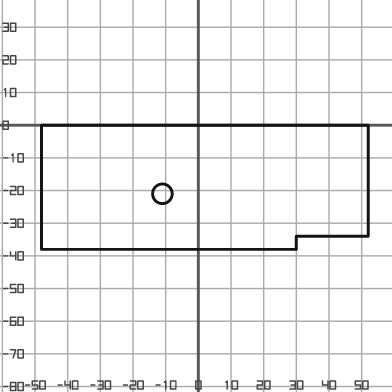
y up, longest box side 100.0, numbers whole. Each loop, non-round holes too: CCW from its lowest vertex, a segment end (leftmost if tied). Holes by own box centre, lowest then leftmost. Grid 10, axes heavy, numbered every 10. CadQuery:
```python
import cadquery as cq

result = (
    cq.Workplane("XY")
    .moveTo(-48.0, -38.0)
    .lineTo(30.0, -38.0)
    .lineTo(30.0, -34.0)
    .lineTo(52.0, -34.0)
    .lineTo(52.0, 0.0)
    .lineTo(-48.0, 0.0)
    .close()
    .moveTo(-11.0, -21.0)
    .circle(3.0)
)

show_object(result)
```